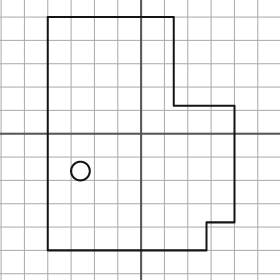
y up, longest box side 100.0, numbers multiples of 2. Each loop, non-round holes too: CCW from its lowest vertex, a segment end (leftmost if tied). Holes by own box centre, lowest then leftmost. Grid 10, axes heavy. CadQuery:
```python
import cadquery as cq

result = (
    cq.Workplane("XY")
    .moveTo(-40.0, -50.0)
    .lineTo(28.0, -50.0)
    .lineTo(28.0, -38.0)
    .lineTo(40.0, -38.0)
    .lineTo(40.0, 12.0)
    .lineTo(14.0, 12.0)
    .lineTo(14.0, 50.0)
    .lineTo(-40.0, 50.0)
    .close()
    .moveTo(-26.0, -16.0)
    .circle(4.0)
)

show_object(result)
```